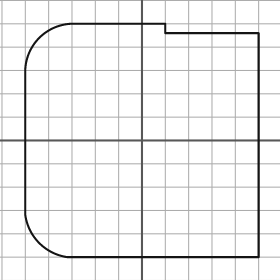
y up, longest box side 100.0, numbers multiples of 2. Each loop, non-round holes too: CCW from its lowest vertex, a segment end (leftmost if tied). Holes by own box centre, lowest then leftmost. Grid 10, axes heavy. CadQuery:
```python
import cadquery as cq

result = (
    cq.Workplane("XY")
    .moveTo(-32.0, -50.0)
    .lineTo(50.0, -50.0)
    .lineTo(50.0, 46.0)
    .lineTo(10.0, 46.0)
    .lineTo(10.0, 50.0)
    .lineTo(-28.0, 50.0)
    .threePointArc((-44.0, 44.0), (-50.0, 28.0))
    .lineTo(-50.0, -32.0)
    .threePointArc((-44.0, -44.0), (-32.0, -50.0))
    .close()
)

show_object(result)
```